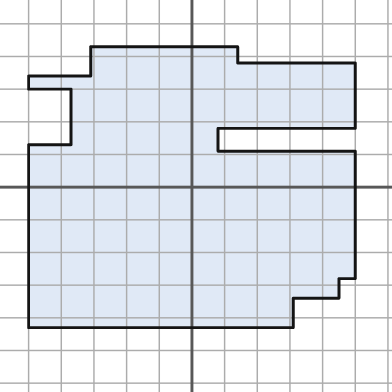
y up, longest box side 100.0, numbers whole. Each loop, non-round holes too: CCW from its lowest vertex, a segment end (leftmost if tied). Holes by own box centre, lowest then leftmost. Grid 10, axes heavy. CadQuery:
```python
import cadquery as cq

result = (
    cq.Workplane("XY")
    .moveTo(-50.0, -43.0)
    .lineTo(31.0, -43.0)
    .lineTo(31.0, -34.0)
    .lineTo(45.0, -34.0)
    .lineTo(45.0, -28.0)
    .lineTo(50.0, -28.0)
    .lineTo(50.0, 11.0)
    .lineTo(8.0, 11.0)
    .lineTo(8.0, 18.0)
    .lineTo(50.0, 18.0)
    .lineTo(50.0, 38.0)
    .lineTo(14.0, 38.0)
    .lineTo(14.0, 43.0)
    .lineTo(-31.0, 43.0)
    .lineTo(-31.0, 34.0)
    .lineTo(-50.0, 34.0)
    .lineTo(-50.0, 30.0)
    .lineTo(-37.0, 30.0)
    .lineTo(-37.0, 13.0)
    .lineTo(-50.0, 13.0)
    .close()
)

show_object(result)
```